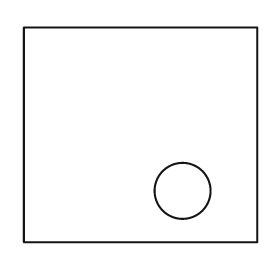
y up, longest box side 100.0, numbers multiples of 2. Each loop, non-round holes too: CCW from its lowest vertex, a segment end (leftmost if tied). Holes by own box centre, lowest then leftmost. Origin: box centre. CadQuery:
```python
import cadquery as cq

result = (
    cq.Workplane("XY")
    .moveTo(-50.0, -46.0)
    .lineTo(50.0, -46.0)
    .lineTo(50.0, 46.0)
    .lineTo(-50.0, 46.0)
    .close()
    .moveTo(18.0, -24.0)
    .circle(12.0)
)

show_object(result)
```